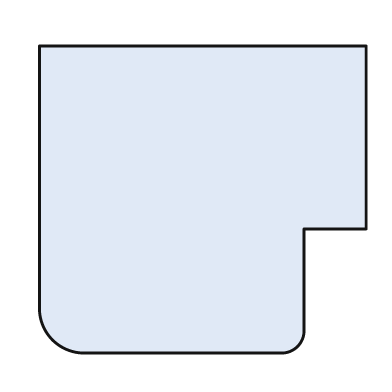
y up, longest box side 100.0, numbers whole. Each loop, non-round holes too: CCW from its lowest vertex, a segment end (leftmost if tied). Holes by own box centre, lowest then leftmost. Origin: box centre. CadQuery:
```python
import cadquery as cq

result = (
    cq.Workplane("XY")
    .moveTo(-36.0, -47.0)
    .lineTo(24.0, -47.0)
    .threePointArc((29.0, -45.0), (31.0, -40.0))
    .lineTo(31.0, -9.0)
    .lineTo(50.0, -9.0)
    .lineTo(50.0, 47.0)
    .lineTo(-50.0, 47.0)
    .lineTo(-50.0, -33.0)
    .threePointArc((-46.0, -43.0), (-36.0, -47.0))
    .close()
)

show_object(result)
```